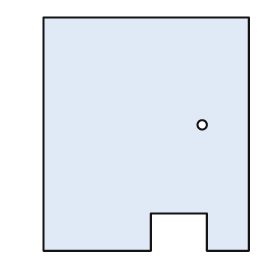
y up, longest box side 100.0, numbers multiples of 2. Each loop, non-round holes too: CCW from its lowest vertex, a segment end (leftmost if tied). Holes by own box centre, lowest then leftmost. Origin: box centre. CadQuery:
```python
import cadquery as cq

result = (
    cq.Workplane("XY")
    .moveTo(-44.0, -50.0)
    .lineTo(2.0, -50.0)
    .lineTo(2.0, -34.0)
    .lineTo(26.0, -34.0)
    .lineTo(26.0, -50.0)
    .lineTo(44.0, -50.0)
    .lineTo(44.0, 50.0)
    .lineTo(-44.0, 50.0)
    .close()
    .moveTo(24.0, 4.0)
    .circle(2.0)
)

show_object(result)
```